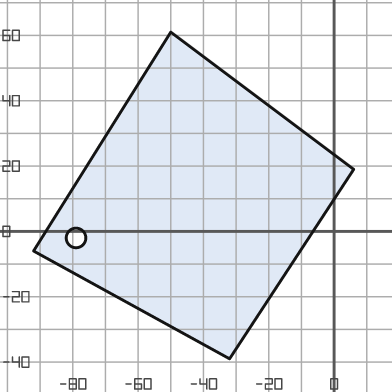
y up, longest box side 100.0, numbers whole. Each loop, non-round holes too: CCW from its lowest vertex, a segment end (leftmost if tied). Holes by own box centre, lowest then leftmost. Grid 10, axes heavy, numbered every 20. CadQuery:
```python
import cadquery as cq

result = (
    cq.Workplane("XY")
    .moveTo(-32.0, -39.0)
    .lineTo(6.0, 19.0)
    .lineTo(-50.0, 61.0)
    .lineTo(-92.0, -6.0)
    .close()
    .moveTo(-79.0, -2.0)
    .circle(3.0)
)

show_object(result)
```